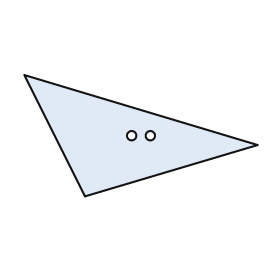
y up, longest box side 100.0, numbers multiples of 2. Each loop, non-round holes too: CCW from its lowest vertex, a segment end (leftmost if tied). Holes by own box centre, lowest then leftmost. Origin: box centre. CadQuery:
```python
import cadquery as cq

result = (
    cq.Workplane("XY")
    .moveTo(-24.0, -26.0)
    .lineTo(50.0, -4.0)
    .lineTo(-50.0, 26.0)
    .close()
    .moveTo(-4.0, 0.0)
    .circle(2.0)
    .moveTo(4.0, 0.0)
    .circle(2.0)
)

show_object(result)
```